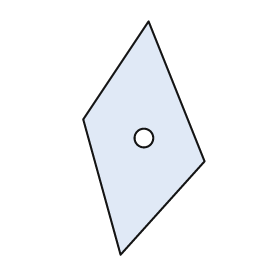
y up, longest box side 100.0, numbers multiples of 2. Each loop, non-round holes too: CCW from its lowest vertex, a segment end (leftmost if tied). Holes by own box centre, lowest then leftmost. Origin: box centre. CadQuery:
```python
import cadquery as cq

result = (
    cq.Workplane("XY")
    .moveTo(-10.0, -50.0)
    .lineTo(26.0, -10.0)
    .lineTo(2.0, 50.0)
    .lineTo(-26.0, 8.0)
    .close()
    .moveTo(0.0, 0.0)
    .circle(4.0)
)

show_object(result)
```